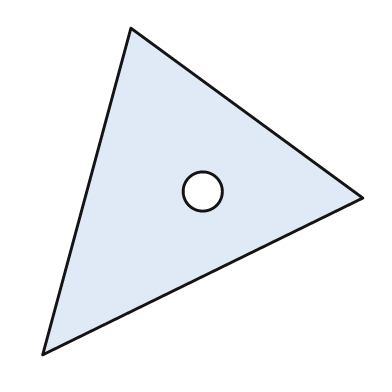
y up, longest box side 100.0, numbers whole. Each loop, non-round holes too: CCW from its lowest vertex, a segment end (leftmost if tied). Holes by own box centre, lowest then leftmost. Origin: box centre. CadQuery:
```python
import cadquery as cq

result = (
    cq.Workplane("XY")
    .moveTo(-49.0, -50.0)
    .lineTo(49.0, -2.0)
    .lineTo(-22.0, 50.0)
    .close()
    .moveTo(0.0, 0.0)
    .circle(6.0)
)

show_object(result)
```